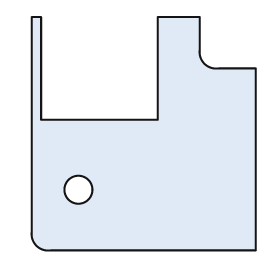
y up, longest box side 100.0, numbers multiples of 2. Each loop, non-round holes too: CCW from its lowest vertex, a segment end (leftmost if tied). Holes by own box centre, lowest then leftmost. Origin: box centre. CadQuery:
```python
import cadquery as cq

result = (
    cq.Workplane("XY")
    .moveTo(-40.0, -50.0)
    .lineTo(48.0, -50.0)
    .lineTo(48.0, 28.0)
    .lineTo(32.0, 28.0)
    .threePointArc((26.0, 30.0), (24.0, 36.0))
    .lineTo(24.0, 50.0)
    .lineTo(6.0, 50.0)
    .lineTo(6.0, 6.0)
    .lineTo(-44.0, 6.0)
    .lineTo(-44.0, 50.0)
    .lineTo(-48.0, 50.0)
    .lineTo(-48.0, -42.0)
    .threePointArc((-46.0, -48.0), (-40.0, -50.0))
    .close()
    .moveTo(-28.0, -24.0)
    .circle(6.0)
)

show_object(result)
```